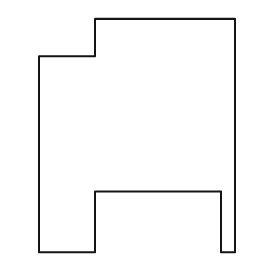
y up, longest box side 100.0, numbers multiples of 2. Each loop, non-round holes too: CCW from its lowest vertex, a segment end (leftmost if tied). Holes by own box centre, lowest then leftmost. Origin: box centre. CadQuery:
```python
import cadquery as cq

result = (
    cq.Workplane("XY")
    .moveTo(-42.0, -50.0)
    .lineTo(-18.0, -50.0)
    .lineTo(-18.0, -24.0)
    .lineTo(36.0, -24.0)
    .lineTo(36.0, -50.0)
    .lineTo(42.0, -50.0)
    .lineTo(42.0, 50.0)
    .lineTo(-18.0, 50.0)
    .lineTo(-18.0, 34.0)
    .lineTo(-42.0, 34.0)
    .close()
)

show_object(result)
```